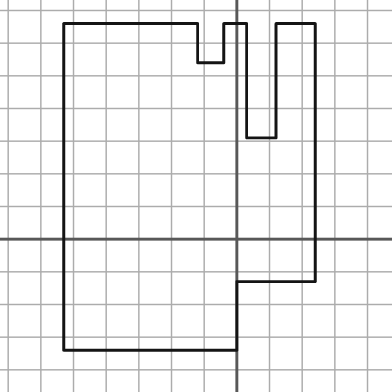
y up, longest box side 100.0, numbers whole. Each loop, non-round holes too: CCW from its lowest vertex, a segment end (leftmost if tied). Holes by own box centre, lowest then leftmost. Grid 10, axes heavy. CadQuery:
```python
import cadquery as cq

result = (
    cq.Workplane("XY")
    .moveTo(-53.0, -34.0)
    .lineTo(0.0, -34.0)
    .lineTo(0.0, -13.0)
    .lineTo(24.0, -13.0)
    .lineTo(24.0, 66.0)
    .lineTo(12.0, 66.0)
    .lineTo(12.0, 31.0)
    .lineTo(3.0, 31.0)
    .lineTo(3.0, 66.0)
    .lineTo(-4.0, 66.0)
    .lineTo(-4.0, 54.0)
    .lineTo(-12.0, 54.0)
    .lineTo(-12.0, 66.0)
    .lineTo(-53.0, 66.0)
    .close()
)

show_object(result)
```